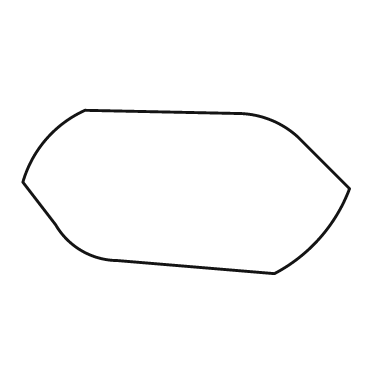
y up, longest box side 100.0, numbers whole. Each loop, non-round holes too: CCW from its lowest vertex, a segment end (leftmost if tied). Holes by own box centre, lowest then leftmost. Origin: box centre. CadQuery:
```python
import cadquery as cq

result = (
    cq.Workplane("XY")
    .moveTo(27.0, -25.0)
    .threePointArc((41.0, -14.0), (50.0, 1.0))
    .lineTo(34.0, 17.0)
    .threePointArc((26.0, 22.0), (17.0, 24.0))
    .lineTo(-31.0, 25.0)
    .threePointArc((-43.0, 16.0), (-50.0, 3.0))
    .lineTo(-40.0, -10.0)
    .threePointArc((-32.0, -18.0), (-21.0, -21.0))
    .close()
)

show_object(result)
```